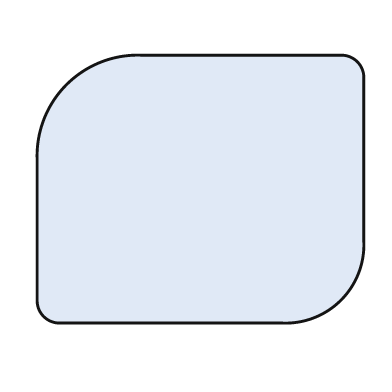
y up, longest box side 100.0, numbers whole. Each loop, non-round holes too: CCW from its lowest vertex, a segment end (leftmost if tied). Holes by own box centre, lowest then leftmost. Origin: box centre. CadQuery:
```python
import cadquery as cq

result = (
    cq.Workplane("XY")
    .moveTo(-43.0, -41.0)
    .lineTo(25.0, -41.0)
    .threePointArc((43.0, -34.0), (50.0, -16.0))
    .lineTo(50.0, 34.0)
    .threePointArc((48.0, 39.0), (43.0, 41.0))
    .lineTo(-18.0, 41.0)
    .threePointArc((-41.0, 32.0), (-50.0, 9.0))
    .lineTo(-50.0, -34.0)
    .threePointArc((-48.0, -39.0), (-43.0, -41.0))
    .close()
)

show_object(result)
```